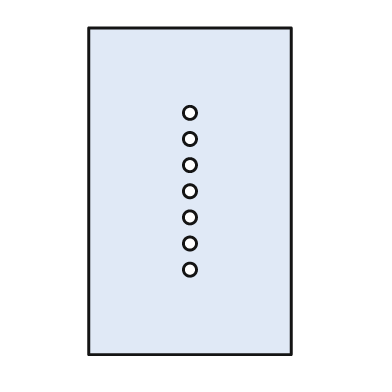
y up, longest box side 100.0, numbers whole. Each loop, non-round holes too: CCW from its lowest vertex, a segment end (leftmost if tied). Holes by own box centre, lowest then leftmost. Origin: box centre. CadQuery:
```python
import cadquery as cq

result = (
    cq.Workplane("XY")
    .moveTo(-31.0, -50.0)
    .lineTo(31.0, -50.0)
    .lineTo(31.0, 50.0)
    .lineTo(-31.0, 50.0)
    .close()
    .moveTo(0.0, -24.0)
    .circle(2.0)
    .moveTo(0.0, -16.0)
    .circle(2.0)
    .moveTo(0.0, -8.0)
    .circle(2.0)
    .moveTo(0.0, 0.0)
    .circle(2.0)
    .moveTo(0.0, 8.0)
    .circle(2.0)
    .moveTo(0.0, 16.0)
    .circle(2.0)
    .moveTo(0.0, 24.0)
    .circle(2.0)
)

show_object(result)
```